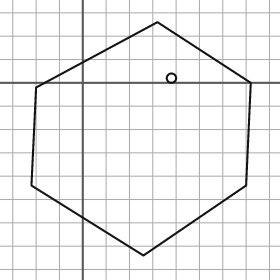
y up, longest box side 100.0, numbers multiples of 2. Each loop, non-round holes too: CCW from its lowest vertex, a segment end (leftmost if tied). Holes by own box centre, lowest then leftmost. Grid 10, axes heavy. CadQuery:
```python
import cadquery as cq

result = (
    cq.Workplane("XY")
    .moveTo(26.0, -74.0)
    .lineTo(70.0, -44.0)
    .lineTo(72.0, 0.0)
    .lineTo(32.0, 26.0)
    .lineTo(-20.0, -2.0)
    .lineTo(-22.0, -44.0)
    .close()
    .moveTo(38.0, 2.0)
    .circle(2.0)
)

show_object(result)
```